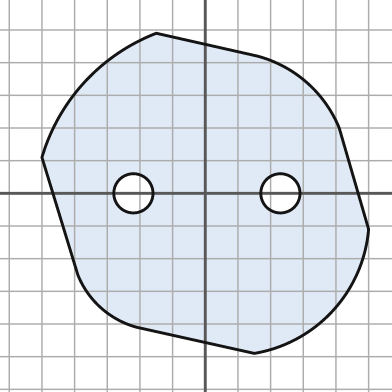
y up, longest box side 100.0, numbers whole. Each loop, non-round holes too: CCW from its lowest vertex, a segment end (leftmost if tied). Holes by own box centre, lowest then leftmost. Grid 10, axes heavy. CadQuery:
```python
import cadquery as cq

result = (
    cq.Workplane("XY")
    .moveTo(15.0, -49.0)
    .threePointArc((39.0, -36.0), (50.0, -11.0))
    .lineTo(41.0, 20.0)
    .threePointArc((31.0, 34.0), (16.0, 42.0))
    .lineTo(-15.0, 49.0)
    .threePointArc((-37.0, 34.0), (-50.0, 11.0))
    .lineTo(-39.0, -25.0)
    .threePointArc((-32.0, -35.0), (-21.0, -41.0))
    .close()
    .moveTo(-22.0, 0.0)
    .circle(6.0)
    .moveTo(23.0, 0.0)
    .circle(6.0)
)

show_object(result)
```